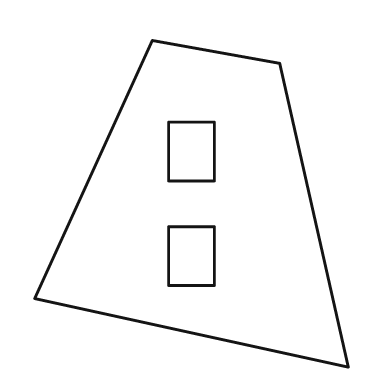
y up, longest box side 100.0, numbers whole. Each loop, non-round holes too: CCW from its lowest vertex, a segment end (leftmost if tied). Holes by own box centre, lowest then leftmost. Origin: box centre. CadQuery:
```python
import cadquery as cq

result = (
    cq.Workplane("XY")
    .moveTo(48.0, -50.0)
    .lineTo(27.0, 43.0)
    .lineTo(-12.0, 50.0)
    .lineTo(-48.0, -29.0)
    .close()
    .moveTo(-7.0, -25.0)
    .lineTo(7.0, -25.0)
    .lineTo(7.0, -7.0)
    .lineTo(-7.0, -7.0)
    .close()
    .moveTo(-7.0, 7.0)
    .lineTo(7.0, 7.0)
    .lineTo(7.0, 25.0)
    .lineTo(-7.0, 25.0)
    .close()
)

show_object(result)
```